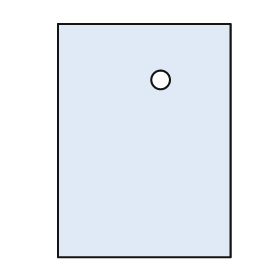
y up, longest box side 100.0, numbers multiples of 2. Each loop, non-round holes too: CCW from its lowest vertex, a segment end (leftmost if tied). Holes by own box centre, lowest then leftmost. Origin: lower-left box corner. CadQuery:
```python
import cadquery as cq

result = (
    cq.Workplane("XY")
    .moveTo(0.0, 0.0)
    .lineTo(74.0, 0.0)
    .lineTo(74.0, 100.0)
    .lineTo(0.0, 100.0)
    .close()
    .moveTo(44.0, 76.0)
    .circle(4.0)
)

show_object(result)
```